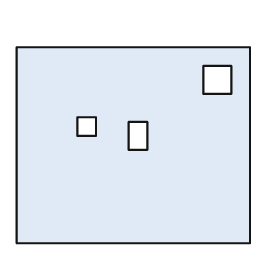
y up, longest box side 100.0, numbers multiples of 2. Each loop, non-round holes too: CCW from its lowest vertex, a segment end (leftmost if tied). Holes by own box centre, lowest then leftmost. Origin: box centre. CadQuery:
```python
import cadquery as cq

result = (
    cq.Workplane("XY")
    .moveTo(-50.0, -42.0)
    .lineTo(50.0, -42.0)
    .lineTo(50.0, 42.0)
    .lineTo(-50.0, 42.0)
    .close()
    .moveTo(-2.0, -2.0)
    .lineTo(6.0, -2.0)
    .lineTo(6.0, 10.0)
    .lineTo(-2.0, 10.0)
    .close()
    .moveTo(-24.0, 4.0)
    .lineTo(-16.0, 4.0)
    .lineTo(-16.0, 12.0)
    .lineTo(-24.0, 12.0)
    .close()
    .moveTo(30.0, 22.0)
    .lineTo(42.0, 22.0)
    .lineTo(42.0, 34.0)
    .lineTo(30.0, 34.0)
    .close()
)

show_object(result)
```